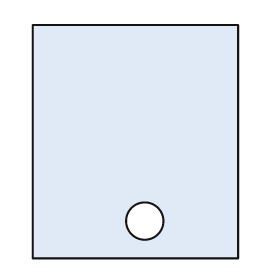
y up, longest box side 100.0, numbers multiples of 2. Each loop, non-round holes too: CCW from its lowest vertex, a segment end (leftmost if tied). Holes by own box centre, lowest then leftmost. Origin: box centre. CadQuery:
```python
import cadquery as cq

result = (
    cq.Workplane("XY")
    .moveTo(-44.0, -50.0)
    .lineTo(44.0, -50.0)
    .lineTo(44.0, 50.0)
    .lineTo(-44.0, 50.0)
    .close()
    .moveTo(4.0, -34.0)
    .circle(8.0)
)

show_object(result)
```